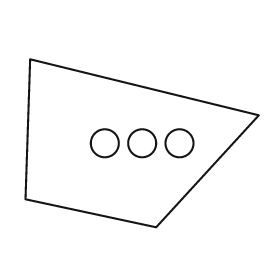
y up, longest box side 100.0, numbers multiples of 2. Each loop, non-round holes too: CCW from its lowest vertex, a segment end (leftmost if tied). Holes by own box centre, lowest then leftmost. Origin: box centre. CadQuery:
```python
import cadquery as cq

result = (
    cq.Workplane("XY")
    .moveTo(6.0, -36.0)
    .lineTo(50.0, 12.0)
    .lineTo(-48.0, 36.0)
    .lineTo(-50.0, -24.0)
    .close()
    .moveTo(-16.0, 0.0)
    .circle(6.0)
    .moveTo(0.0, 0.0)
    .circle(6.0)
    .moveTo(16.0, 0.0)
    .circle(6.0)
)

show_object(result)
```